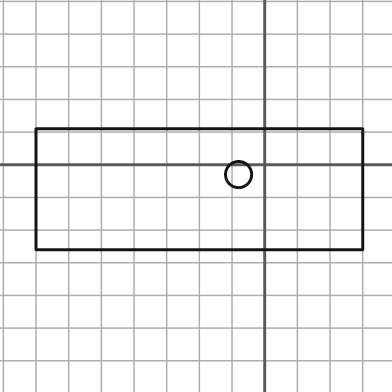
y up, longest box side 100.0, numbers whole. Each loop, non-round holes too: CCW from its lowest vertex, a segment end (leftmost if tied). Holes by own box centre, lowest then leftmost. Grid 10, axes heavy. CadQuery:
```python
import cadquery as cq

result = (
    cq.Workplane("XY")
    .moveTo(-70.0, -26.0)
    .lineTo(30.0, -26.0)
    .lineTo(30.0, 11.0)
    .lineTo(-70.0, 11.0)
    .close()
    .moveTo(-8.0, -3.0)
    .circle(4.0)
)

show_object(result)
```